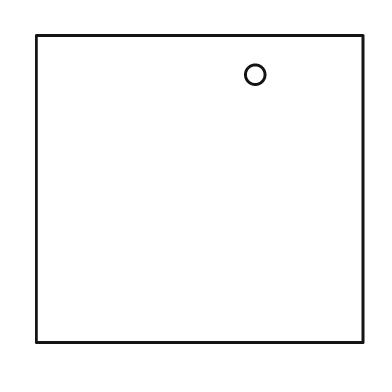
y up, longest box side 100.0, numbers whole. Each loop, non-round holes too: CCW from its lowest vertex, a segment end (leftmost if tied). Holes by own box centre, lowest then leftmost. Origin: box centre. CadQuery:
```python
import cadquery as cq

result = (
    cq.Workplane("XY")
    .moveTo(-50.0, -47.0)
    .lineTo(50.0, -47.0)
    .lineTo(50.0, 47.0)
    .lineTo(-50.0, 47.0)
    .close()
    .moveTo(17.0, 35.0)
    .circle(3.0)
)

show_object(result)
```